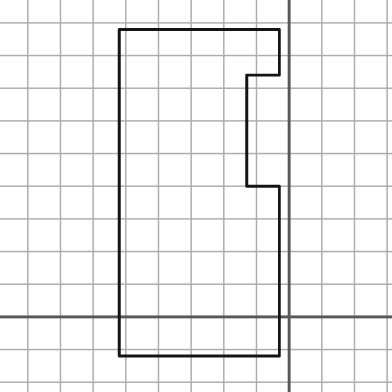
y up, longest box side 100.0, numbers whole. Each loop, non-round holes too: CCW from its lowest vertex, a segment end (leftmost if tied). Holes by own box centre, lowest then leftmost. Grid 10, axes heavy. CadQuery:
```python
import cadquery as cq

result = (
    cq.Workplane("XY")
    .moveTo(-52.0, -12.0)
    .lineTo(-3.0, -12.0)
    .lineTo(-3.0, 40.0)
    .lineTo(-13.0, 40.0)
    .lineTo(-13.0, 74.0)
    .lineTo(-3.0, 74.0)
    .lineTo(-3.0, 88.0)
    .lineTo(-52.0, 88.0)
    .close()
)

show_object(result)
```